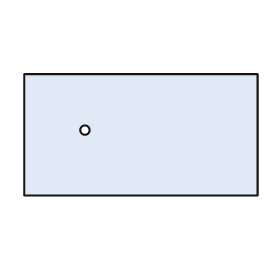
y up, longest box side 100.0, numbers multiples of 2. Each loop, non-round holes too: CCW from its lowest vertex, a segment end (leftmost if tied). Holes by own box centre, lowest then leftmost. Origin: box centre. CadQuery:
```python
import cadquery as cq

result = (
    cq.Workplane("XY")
    .moveTo(-50.0, -26.0)
    .lineTo(50.0, -26.0)
    .lineTo(50.0, 26.0)
    .lineTo(-50.0, 26.0)
    .close()
    .moveTo(-24.0, 2.0)
    .circle(2.0)
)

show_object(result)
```